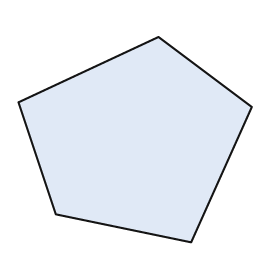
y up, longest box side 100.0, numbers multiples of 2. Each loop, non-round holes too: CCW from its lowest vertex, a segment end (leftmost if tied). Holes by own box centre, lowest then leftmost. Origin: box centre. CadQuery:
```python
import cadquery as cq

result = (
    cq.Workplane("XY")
    .moveTo(24.0, -44.0)
    .lineTo(50.0, 14.0)
    .lineTo(10.0, 44.0)
    .lineTo(-50.0, 16.0)
    .lineTo(-34.0, -32.0)
    .close()
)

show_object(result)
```